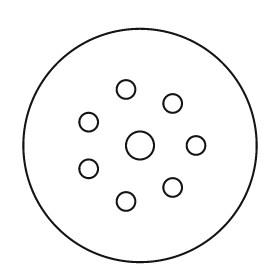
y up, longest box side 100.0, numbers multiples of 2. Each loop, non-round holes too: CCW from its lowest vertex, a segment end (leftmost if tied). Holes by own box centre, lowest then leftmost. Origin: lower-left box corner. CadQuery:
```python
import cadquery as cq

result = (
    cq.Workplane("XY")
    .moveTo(50.0, 50.0)
    .circle(50.0)
    .moveTo(44.0, 26.0)
    .circle(4.0)
    .moveTo(64.0, 32.0)
    .circle(4.0)
    .moveTo(28.0, 40.0)
    .circle(4.0)
    .moveTo(50.0, 50.0)
    .circle(6.0)
    .moveTo(74.0, 50.0)
    .circle(4.0)
    .moveTo(28.0, 60.0)
    .circle(4.0)
    .moveTo(64.0, 68.0)
    .circle(4.0)
    .moveTo(44.0, 74.0)
    .circle(4.0)
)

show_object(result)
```